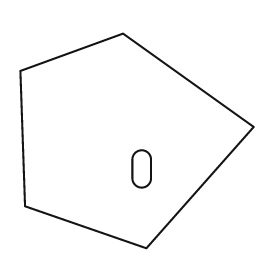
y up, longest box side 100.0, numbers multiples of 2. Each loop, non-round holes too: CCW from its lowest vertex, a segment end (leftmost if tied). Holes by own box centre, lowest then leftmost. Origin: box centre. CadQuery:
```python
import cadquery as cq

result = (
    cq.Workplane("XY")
    .moveTo(4.0, -46.0)
    .lineTo(50.0, 6.0)
    .lineTo(-6.0, 46.0)
    .lineTo(-50.0, 30.0)
    .lineTo(-48.0, -28.0)
    .close()
    .moveTo(-2.0, -16.0)
    .threePointArc((2.0, -20.0), (6.0, -16.0))
    .lineTo(6.0, -8.0)
    .threePointArc((2.0, -4.0), (-2.0, -8.0))
    .close()
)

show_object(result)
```